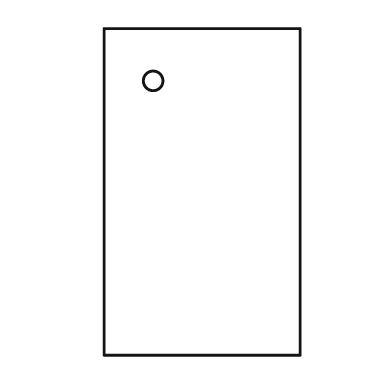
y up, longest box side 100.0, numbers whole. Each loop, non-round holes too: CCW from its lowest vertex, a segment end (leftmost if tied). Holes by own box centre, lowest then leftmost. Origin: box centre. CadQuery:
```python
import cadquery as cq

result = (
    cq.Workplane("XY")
    .moveTo(-30.0, -50.0)
    .lineTo(30.0, -50.0)
    .lineTo(30.0, 50.0)
    .lineTo(-30.0, 50.0)
    .close()
    .moveTo(-15.0, 34.0)
    .circle(3.0)
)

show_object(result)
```